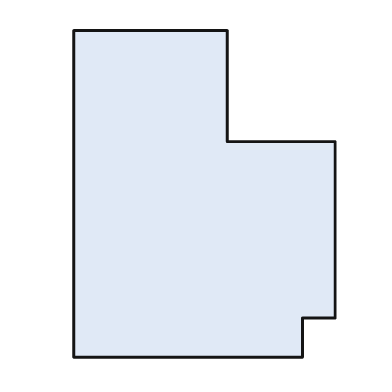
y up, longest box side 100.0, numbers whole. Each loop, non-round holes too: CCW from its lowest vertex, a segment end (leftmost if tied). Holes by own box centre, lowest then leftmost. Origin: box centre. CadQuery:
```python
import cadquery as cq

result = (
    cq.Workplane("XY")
    .moveTo(-40.0, -50.0)
    .lineTo(30.0, -50.0)
    .lineTo(30.0, -38.0)
    .lineTo(40.0, -38.0)
    .lineTo(40.0, 16.0)
    .lineTo(7.0, 16.0)
    .lineTo(7.0, 50.0)
    .lineTo(-40.0, 50.0)
    .close()
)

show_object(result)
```